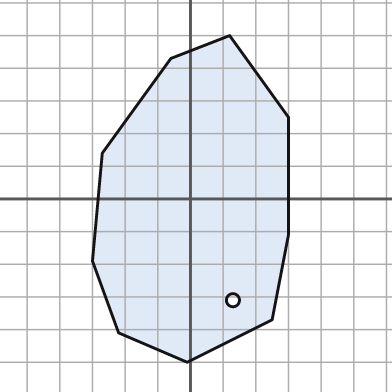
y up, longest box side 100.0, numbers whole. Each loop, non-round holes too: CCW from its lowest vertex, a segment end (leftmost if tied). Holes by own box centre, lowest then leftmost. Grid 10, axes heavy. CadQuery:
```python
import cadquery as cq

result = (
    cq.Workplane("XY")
    .moveTo(-1.0, -50.0)
    .lineTo(25.0, -37.0)
    .lineTo(30.0, -11.0)
    .lineTo(30.0, 25.0)
    .lineTo(12.0, 50.0)
    .lineTo(-6.0, 43.0)
    .lineTo(-27.0, 14.0)
    .lineTo(-30.0, -19.0)
    .lineTo(-22.0, -41.0)
    .close()
    .moveTo(13.0, -31.0)
    .circle(2.0)
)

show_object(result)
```